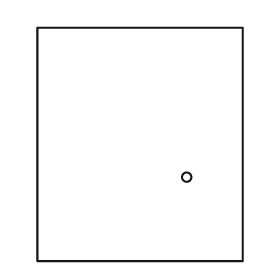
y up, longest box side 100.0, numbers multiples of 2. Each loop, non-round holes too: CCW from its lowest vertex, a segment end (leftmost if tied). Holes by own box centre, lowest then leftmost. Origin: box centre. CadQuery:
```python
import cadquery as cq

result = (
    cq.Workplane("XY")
    .moveTo(-44.0, -50.0)
    .lineTo(44.0, -50.0)
    .lineTo(44.0, 50.0)
    .lineTo(-44.0, 50.0)
    .close()
    .moveTo(20.0, -14.0)
    .circle(2.0)
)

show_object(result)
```